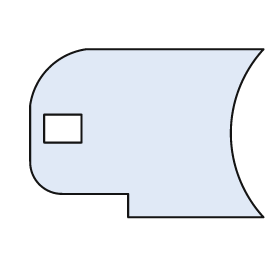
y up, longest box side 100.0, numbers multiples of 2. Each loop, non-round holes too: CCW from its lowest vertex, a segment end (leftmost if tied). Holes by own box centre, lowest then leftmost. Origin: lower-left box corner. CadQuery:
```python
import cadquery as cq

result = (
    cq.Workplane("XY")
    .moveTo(42.0, 0.0)
    .lineTo(100.0, 0.0)
    .threePointArc((86.0, 36.0), (100.0, 72.0))
    .lineTo(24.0, 72.0)
    .threePointArc((8.0, 64.0), (0.0, 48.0))
    .lineTo(0.0, 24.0)
    .threePointArc((4.0, 14.0), (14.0, 10.0))
    .lineTo(42.0, 10.0)
    .close()
    .moveTo(6.0, 32.0)
    .lineTo(22.0, 32.0)
    .lineTo(22.0, 44.0)
    .lineTo(6.0, 44.0)
    .close()
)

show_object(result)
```